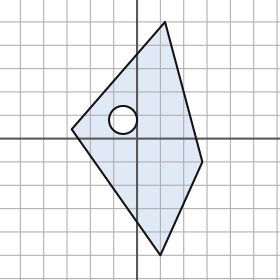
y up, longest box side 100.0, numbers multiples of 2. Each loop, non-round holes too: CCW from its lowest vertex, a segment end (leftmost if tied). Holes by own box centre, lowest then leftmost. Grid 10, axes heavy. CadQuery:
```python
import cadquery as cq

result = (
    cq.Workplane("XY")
    .moveTo(10.0, -50.0)
    .lineTo(28.0, -10.0)
    .lineTo(12.0, 50.0)
    .lineTo(-28.0, 4.0)
    .close()
    .moveTo(-6.0, 8.0)
    .circle(6.0)
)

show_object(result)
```